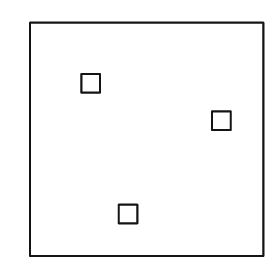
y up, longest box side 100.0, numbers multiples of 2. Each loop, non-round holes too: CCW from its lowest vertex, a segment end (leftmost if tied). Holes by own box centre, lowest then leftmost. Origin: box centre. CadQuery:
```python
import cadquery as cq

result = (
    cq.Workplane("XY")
    .moveTo(-50.0, -50.0)
    .lineTo(50.0, -50.0)
    .lineTo(50.0, 50.0)
    .lineTo(-50.0, 50.0)
    .close()
    .moveTo(-12.0, -36.0)
    .lineTo(-4.0, -36.0)
    .lineTo(-4.0, -28.0)
    .lineTo(-12.0, -28.0)
    .close()
    .moveTo(28.0, 4.0)
    .lineTo(36.0, 4.0)
    .lineTo(36.0, 12.0)
    .lineTo(28.0, 12.0)
    .close()
    .moveTo(-28.0, 20.0)
    .lineTo(-20.0, 20.0)
    .lineTo(-20.0, 28.0)
    .lineTo(-28.0, 28.0)
    .close()
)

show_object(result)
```